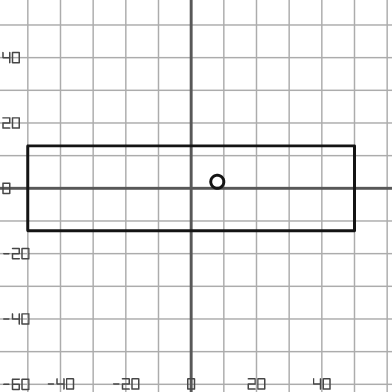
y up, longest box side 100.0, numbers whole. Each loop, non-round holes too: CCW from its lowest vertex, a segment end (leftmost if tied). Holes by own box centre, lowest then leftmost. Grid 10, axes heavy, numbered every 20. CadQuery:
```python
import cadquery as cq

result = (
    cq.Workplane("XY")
    .moveTo(-50.0, -13.0)
    .lineTo(50.0, -13.0)
    .lineTo(50.0, 13.0)
    .lineTo(-50.0, 13.0)
    .close()
    .moveTo(8.0, 2.0)
    .circle(2.0)
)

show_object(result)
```